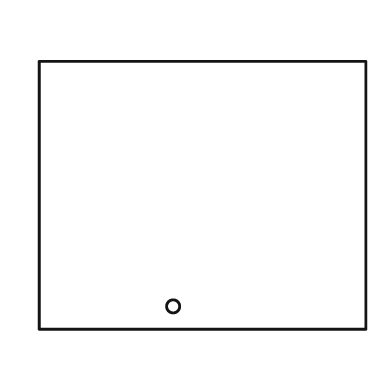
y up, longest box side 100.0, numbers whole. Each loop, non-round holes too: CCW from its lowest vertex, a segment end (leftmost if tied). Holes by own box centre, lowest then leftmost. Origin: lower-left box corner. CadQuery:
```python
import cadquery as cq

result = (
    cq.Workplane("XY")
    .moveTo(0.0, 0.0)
    .lineTo(100.0, 0.0)
    .lineTo(100.0, 82.0)
    .lineTo(0.0, 82.0)
    .close()
    .moveTo(41.0, 7.0)
    .circle(2.0)
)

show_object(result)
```